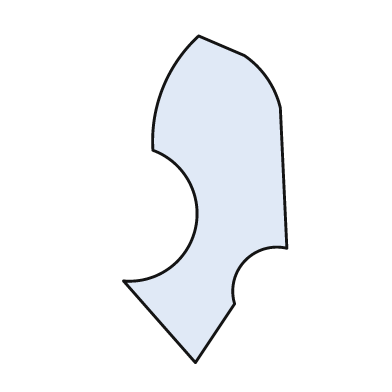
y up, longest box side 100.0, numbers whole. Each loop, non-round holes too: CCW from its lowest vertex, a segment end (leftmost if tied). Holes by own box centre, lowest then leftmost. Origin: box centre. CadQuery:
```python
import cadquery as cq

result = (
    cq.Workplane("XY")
    .moveTo(-3.0, -50.0)
    .lineTo(9.0, -32.0)
    .threePointArc((12.0, -19.0), (25.0, -15.0))
    .lineTo(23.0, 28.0)
    .threePointArc((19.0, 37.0), (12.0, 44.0))
    .lineTo(-2.0, 50.0)
    .threePointArc((-13.0, 34.0), (-16.0, 15.0))
    .threePointArc((-3.0, -9.0), (-25.0, -25.0))
    .close()
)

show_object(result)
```